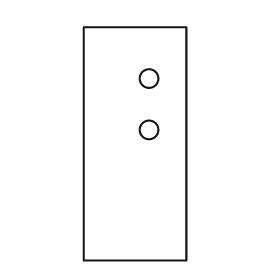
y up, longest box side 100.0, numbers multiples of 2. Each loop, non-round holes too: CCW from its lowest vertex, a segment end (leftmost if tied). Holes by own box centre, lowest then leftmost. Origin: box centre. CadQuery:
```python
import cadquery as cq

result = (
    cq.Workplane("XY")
    .moveTo(-22.0, -50.0)
    .lineTo(22.0, -50.0)
    .lineTo(22.0, 50.0)
    .lineTo(-22.0, 50.0)
    .close()
    .moveTo(6.0, 6.0)
    .circle(4.0)
    .moveTo(6.0, 28.0)
    .circle(4.0)
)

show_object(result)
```